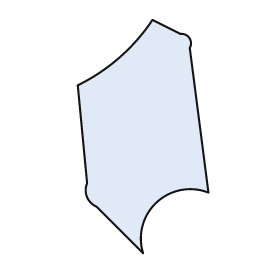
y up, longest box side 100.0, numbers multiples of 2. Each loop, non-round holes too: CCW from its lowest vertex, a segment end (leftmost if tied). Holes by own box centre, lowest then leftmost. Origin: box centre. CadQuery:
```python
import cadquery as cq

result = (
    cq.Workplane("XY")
    .moveTo(0.0, -50.0)
    .threePointArc((6.0, -28.0), (28.0, -24.0))
    .lineTo(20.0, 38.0)
    .threePointArc((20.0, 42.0), (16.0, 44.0))
    .lineTo(4.0, 50.0)
    .threePointArc((-10.0, 34.0), (-28.0, 22.0))
    .lineTo(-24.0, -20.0)
    .threePointArc((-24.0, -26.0), (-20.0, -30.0))
    .close()
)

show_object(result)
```